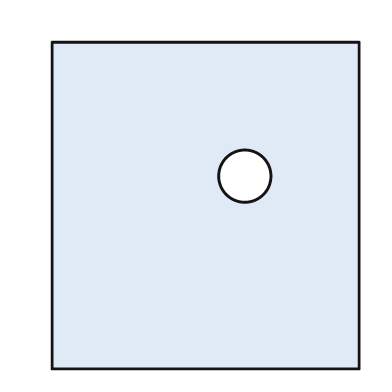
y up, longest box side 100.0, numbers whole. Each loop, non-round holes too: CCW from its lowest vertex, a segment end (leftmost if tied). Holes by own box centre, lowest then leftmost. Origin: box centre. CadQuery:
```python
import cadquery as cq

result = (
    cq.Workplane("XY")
    .moveTo(-47.0, -50.0)
    .lineTo(47.0, -50.0)
    .lineTo(47.0, 50.0)
    .lineTo(-47.0, 50.0)
    .close()
    .moveTo(12.0, 9.0)
    .circle(8.0)
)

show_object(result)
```